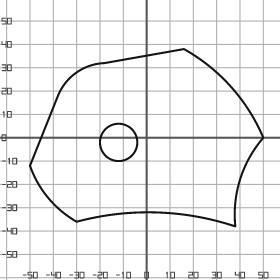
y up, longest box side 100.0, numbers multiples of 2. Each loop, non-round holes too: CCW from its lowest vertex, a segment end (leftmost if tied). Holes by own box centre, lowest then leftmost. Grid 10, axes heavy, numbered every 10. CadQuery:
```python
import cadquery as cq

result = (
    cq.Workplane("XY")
    .moveTo(38.0, -38.0)
    .threePointArc((40.0, -18.0), (50.0, 0.0))
    .threePointArc((36.0, 22.0), (16.0, 38.0))
    .lineTo(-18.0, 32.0)
    .threePointArc((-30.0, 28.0), (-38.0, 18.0))
    .lineTo(-50.0, -12.0)
    .threePointArc((-42.0, -26.0), (-30.0, -36.0))
    .threePointArc((4.0, -32.0), (38.0, -38.0))
    .close()
    .moveTo(-12.0, -2.0)
    .circle(8.0)
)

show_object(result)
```